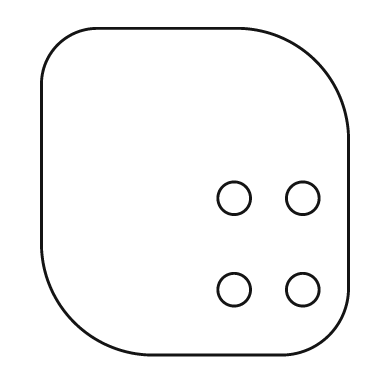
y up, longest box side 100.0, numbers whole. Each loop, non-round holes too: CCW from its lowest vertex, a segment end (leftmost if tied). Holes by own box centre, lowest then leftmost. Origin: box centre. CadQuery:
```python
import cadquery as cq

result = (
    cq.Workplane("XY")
    .moveTo(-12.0, -50.0)
    .lineTo(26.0, -50.0)
    .threePointArc((41.0, -44.0), (47.0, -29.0))
    .lineTo(47.0, 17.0)
    .threePointArc((37.0, 40.0), (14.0, 50.0))
    .lineTo(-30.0, 50.0)
    .threePointArc((-42.0, 45.0), (-47.0, 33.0))
    .lineTo(-47.0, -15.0)
    .threePointArc((-37.0, -40.0), (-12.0, -50.0))
    .close()
    .moveTo(12.0, -30.0)
    .circle(5.0)
    .moveTo(33.0, -30.0)
    .circle(5.0)
    .moveTo(12.0, -2.0)
    .circle(5.0)
    .moveTo(33.0, -2.0)
    .circle(5.0)
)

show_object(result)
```